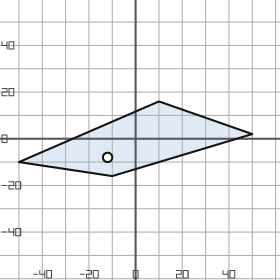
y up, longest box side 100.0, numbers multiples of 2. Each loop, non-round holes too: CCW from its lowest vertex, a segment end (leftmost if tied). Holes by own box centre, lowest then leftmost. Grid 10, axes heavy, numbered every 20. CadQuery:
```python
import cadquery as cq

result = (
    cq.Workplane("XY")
    .moveTo(-10.0, -16.0)
    .lineTo(50.0, 2.0)
    .lineTo(10.0, 16.0)
    .lineTo(-50.0, -10.0)
    .close()
    .moveTo(-12.0, -8.0)
    .circle(2.0)
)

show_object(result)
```